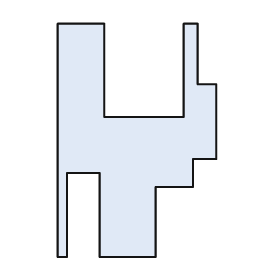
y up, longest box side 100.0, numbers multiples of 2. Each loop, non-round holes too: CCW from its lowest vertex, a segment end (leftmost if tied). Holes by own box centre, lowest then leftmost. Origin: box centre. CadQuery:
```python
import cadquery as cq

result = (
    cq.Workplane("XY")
    .moveTo(-34.0, -50.0)
    .lineTo(-30.0, -50.0)
    .lineTo(-30.0, -14.0)
    .lineTo(-16.0, -14.0)
    .lineTo(-16.0, -50.0)
    .lineTo(8.0, -50.0)
    .lineTo(8.0, -20.0)
    .lineTo(24.0, -20.0)
    .lineTo(24.0, -8.0)
    .lineTo(34.0, -8.0)
    .lineTo(34.0, 24.0)
    .lineTo(26.0, 24.0)
    .lineTo(26.0, 50.0)
    .lineTo(20.0, 50.0)
    .lineTo(20.0, 10.0)
    .lineTo(-14.0, 10.0)
    .lineTo(-14.0, 50.0)
    .lineTo(-34.0, 50.0)
    .close()
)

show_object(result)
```